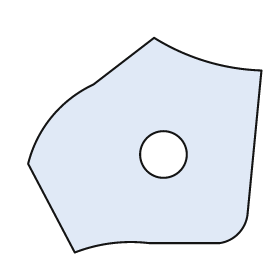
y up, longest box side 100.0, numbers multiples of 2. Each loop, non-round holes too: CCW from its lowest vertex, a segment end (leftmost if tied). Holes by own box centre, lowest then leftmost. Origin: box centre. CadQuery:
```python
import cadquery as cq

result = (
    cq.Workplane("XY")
    .moveTo(-30.0, -46.0)
    .threePointArc((-14.0, -42.0), (2.0, -42.0))
    .lineTo(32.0, -42.0)
    .threePointArc((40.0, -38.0), (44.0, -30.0))
    .lineTo(50.0, 32.0)
    .threePointArc((26.0, 36.0), (4.0, 46.0))
    .lineTo(-22.0, 26.0)
    .threePointArc((-40.0, 12.0), (-50.0, -8.0))
    .close()
    .moveTo(8.0, -4.0)
    .circle(10.0)
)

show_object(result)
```